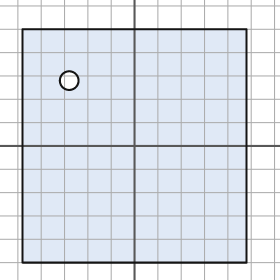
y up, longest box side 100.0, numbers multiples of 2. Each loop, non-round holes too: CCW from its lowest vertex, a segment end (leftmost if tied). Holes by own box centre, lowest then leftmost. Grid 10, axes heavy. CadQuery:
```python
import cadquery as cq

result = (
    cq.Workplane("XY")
    .moveTo(-48.0, -50.0)
    .lineTo(48.0, -50.0)
    .lineTo(48.0, 50.0)
    .lineTo(-48.0, 50.0)
    .close()
    .moveTo(-28.0, 28.0)
    .circle(4.0)
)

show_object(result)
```